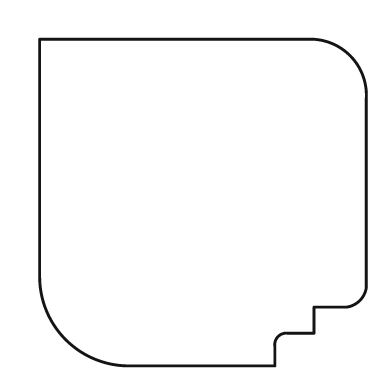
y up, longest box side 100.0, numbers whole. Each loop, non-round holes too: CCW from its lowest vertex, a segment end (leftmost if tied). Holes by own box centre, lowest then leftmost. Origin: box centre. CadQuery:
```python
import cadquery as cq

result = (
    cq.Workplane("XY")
    .moveTo(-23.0, -50.0)
    .lineTo(22.0, -50.0)
    .lineTo(22.0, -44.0)
    .threePointArc((23.0, -41.0), (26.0, -40.0))
    .lineTo(34.0, -40.0)
    .lineTo(34.0, -32.0)
    .lineTo(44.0, -32.0)
    .threePointArc((48.0, -30.0), (50.0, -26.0))
    .lineTo(50.0, 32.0)
    .threePointArc((45.0, 45.0), (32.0, 50.0))
    .lineTo(-50.0, 50.0)
    .lineTo(-50.0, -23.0)
    .threePointArc((-42.0, -42.0), (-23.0, -50.0))
    .close()
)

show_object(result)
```